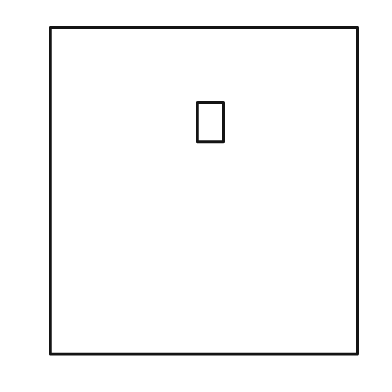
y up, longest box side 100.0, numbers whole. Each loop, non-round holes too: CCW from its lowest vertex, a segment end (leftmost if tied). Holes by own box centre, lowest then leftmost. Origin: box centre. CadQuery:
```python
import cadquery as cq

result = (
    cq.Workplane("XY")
    .moveTo(-47.0, -50.0)
    .lineTo(47.0, -50.0)
    .lineTo(47.0, 50.0)
    .lineTo(-47.0, 50.0)
    .close()
    .moveTo(-2.0, 15.0)
    .lineTo(6.0, 15.0)
    .lineTo(6.0, 27.0)
    .lineTo(-2.0, 27.0)
    .close()
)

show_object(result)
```